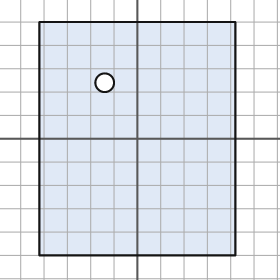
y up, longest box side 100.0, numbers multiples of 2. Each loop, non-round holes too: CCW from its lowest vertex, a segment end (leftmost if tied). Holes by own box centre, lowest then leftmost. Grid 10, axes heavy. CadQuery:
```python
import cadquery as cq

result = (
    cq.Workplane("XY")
    .moveTo(-42.0, -50.0)
    .lineTo(42.0, -50.0)
    .lineTo(42.0, 50.0)
    .lineTo(-42.0, 50.0)
    .close()
    .moveTo(-14.0, 24.0)
    .circle(4.0)
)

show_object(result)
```